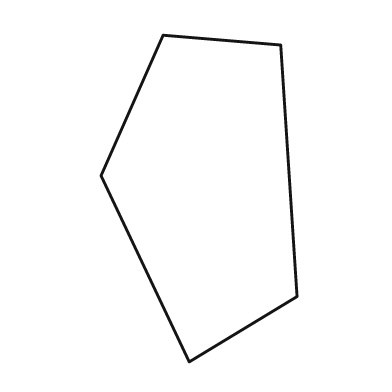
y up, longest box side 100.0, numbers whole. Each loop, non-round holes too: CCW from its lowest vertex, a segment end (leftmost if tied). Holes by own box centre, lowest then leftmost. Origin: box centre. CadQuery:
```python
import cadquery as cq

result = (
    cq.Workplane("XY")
    .moveTo(-3.0, -50.0)
    .lineTo(30.0, -30.0)
    .lineTo(25.0, 47.0)
    .lineTo(-11.0, 50.0)
    .lineTo(-30.0, 7.0)
    .close()
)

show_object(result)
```